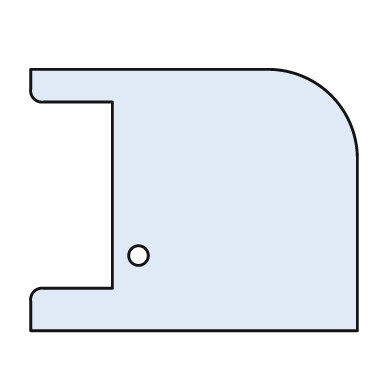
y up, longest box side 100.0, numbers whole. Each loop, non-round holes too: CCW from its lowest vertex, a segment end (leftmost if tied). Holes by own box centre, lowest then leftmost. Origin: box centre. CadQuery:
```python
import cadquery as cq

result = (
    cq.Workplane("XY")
    .moveTo(-50.0, -40.0)
    .lineTo(50.0, -40.0)
    .lineTo(50.0, 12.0)
    .threePointArc((42.0, 32.0), (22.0, 40.0))
    .lineTo(-50.0, 40.0)
    .lineTo(-50.0, 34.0)
    .threePointArc((-49.0, 31.0), (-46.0, 30.0))
    .lineTo(-25.0, 30.0)
    .lineTo(-25.0, -27.0)
    .lineTo(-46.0, -27.0)
    .threePointArc((-49.0, -28.0), (-50.0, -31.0))
    .close()
    .moveTo(-17.0, -17.0)
    .circle(3.0)
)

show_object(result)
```